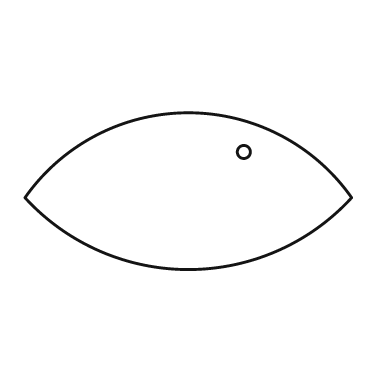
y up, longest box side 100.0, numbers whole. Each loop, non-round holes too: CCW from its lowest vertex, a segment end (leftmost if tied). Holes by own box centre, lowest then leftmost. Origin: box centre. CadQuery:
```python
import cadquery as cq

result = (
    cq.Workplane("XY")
    .moveTo(-50.0, -2.0)
    .threePointArc((0.0, -24.0), (50.0, -2.0))
    .threePointArc((0.0, 24.0), (-50.0, -2.0))
    .close()
    .moveTo(17.0, 12.0)
    .circle(2.0)
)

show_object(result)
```